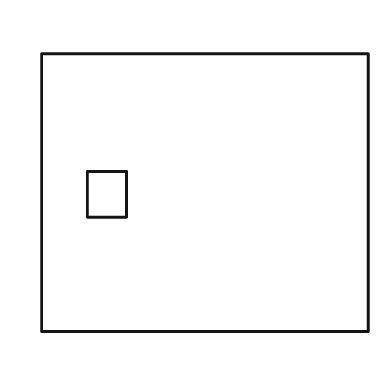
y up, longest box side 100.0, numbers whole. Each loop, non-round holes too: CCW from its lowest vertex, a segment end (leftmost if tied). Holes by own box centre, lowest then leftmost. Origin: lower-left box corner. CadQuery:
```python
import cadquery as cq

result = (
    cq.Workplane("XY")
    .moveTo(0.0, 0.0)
    .lineTo(100.0, 0.0)
    .lineTo(100.0, 85.0)
    .lineTo(0.0, 85.0)
    .close()
    .moveTo(14.0, 35.0)
    .lineTo(26.0, 35.0)
    .lineTo(26.0, 49.0)
    .lineTo(14.0, 49.0)
    .close()
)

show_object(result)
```